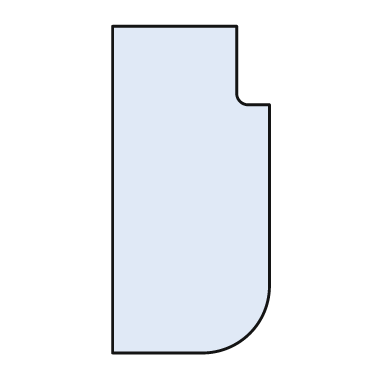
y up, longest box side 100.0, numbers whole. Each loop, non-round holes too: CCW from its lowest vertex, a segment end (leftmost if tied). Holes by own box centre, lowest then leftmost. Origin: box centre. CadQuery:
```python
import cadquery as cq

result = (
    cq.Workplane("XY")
    .moveTo(-24.0, -50.0)
    .lineTo(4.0, -50.0)
    .threePointArc((18.0, -44.0), (24.0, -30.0))
    .lineTo(24.0, 26.0)
    .lineTo(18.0, 26.0)
    .threePointArc((15.0, 27.0), (14.0, 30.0))
    .lineTo(14.0, 50.0)
    .lineTo(-24.0, 50.0)
    .close()
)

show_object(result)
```